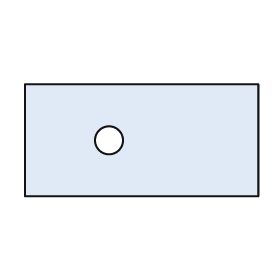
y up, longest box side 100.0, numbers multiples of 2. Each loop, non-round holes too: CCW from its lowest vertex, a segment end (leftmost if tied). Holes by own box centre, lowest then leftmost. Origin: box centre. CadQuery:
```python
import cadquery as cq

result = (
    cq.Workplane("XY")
    .moveTo(-50.0, -24.0)
    .lineTo(50.0, -24.0)
    .lineTo(50.0, 24.0)
    .lineTo(-50.0, 24.0)
    .close()
    .moveTo(-14.0, 0.0)
    .circle(6.0)
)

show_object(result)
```